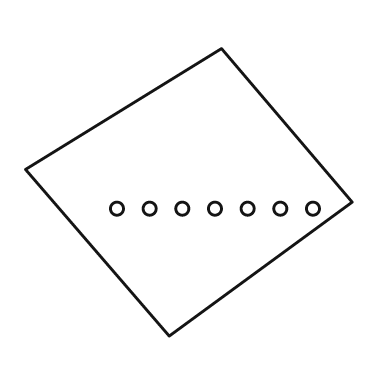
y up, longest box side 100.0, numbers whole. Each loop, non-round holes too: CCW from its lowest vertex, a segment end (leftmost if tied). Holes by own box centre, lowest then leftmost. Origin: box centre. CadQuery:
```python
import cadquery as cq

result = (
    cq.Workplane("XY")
    .moveTo(-6.0, -44.0)
    .lineTo(50.0, -3.0)
    .lineTo(10.0, 44.0)
    .lineTo(-50.0, 7.0)
    .close()
    .moveTo(-22.0, -5.0)
    .circle(2.0)
    .moveTo(-12.0, -5.0)
    .circle(2.0)
    .moveTo(-2.0, -5.0)
    .circle(2.0)
    .moveTo(8.0, -5.0)
    .circle(2.0)
    .moveTo(18.0, -5.0)
    .circle(2.0)
    .moveTo(28.0, -5.0)
    .circle(2.0)
    .moveTo(38.0, -5.0)
    .circle(2.0)
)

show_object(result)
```